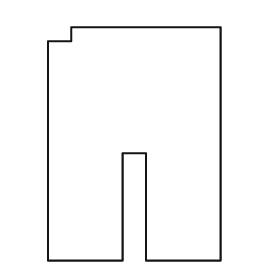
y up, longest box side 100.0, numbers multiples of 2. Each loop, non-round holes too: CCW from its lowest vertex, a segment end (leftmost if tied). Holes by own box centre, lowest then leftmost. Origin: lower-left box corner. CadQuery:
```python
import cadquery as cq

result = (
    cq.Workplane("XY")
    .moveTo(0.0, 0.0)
    .lineTo(32.0, 0.0)
    .lineTo(32.0, 46.0)
    .lineTo(42.0, 46.0)
    .lineTo(42.0, 0.0)
    .lineTo(74.0, 0.0)
    .lineTo(74.0, 100.0)
    .lineTo(10.0, 100.0)
    .lineTo(10.0, 94.0)
    .lineTo(0.0, 94.0)
    .close()
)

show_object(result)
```